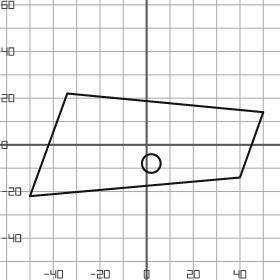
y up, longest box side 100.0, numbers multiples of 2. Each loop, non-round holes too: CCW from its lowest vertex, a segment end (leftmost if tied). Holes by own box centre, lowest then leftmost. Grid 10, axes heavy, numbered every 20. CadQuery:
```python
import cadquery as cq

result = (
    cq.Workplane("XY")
    .moveTo(-50.0, -22.0)
    .lineTo(40.0, -14.0)
    .lineTo(50.0, 14.0)
    .lineTo(-34.0, 22.0)
    .close()
    .moveTo(2.0, -8.0)
    .circle(4.0)
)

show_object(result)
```